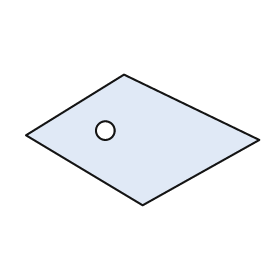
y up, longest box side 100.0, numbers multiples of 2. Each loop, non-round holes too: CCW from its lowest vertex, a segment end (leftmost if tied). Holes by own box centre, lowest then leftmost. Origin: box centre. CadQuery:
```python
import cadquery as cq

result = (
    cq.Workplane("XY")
    .moveTo(0.0, -28.0)
    .lineTo(50.0, 0.0)
    .lineTo(-8.0, 28.0)
    .lineTo(-50.0, 2.0)
    .close()
    .moveTo(-16.0, 4.0)
    .circle(4.0)
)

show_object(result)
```